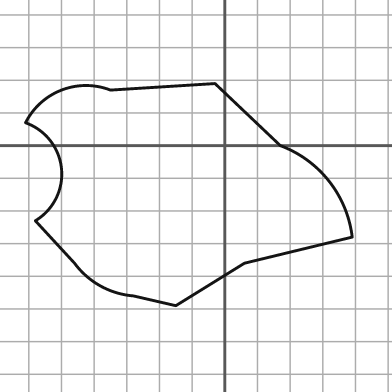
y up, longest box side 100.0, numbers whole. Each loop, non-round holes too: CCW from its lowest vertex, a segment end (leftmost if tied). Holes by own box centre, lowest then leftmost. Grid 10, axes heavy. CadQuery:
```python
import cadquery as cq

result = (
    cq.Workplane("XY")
    .moveTo(-15.0, -49.0)
    .lineTo(6.0, -36.0)
    .lineTo(39.0, -28.0)
    .threePointArc((32.0, -11.0), (17.0, 0.0))
    .lineTo(-3.0, 19.0)
    .lineTo(-35.0, 17.0)
    .threePointArc((-50.0, 17.0), (-61.0, 7.0))
    .threePointArc((-50.0, -7.0), (-58.0, -23.0))
    .lineTo(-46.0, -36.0)
    .threePointArc((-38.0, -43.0), (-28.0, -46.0))
    .close()
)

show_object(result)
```